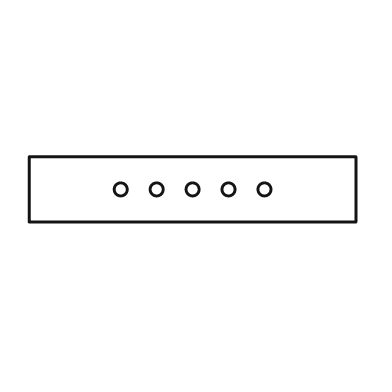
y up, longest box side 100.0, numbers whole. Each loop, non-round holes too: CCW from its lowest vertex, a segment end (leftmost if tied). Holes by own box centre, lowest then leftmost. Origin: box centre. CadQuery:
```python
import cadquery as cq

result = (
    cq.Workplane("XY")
    .moveTo(-50.0, -10.0)
    .lineTo(50.0, -10.0)
    .lineTo(50.0, 10.0)
    .lineTo(-50.0, 10.0)
    .close()
    .moveTo(-22.0, 0.0)
    .circle(2.0)
    .moveTo(-11.0, 0.0)
    .circle(2.0)
    .moveTo(0.0, 0.0)
    .circle(2.0)
    .moveTo(11.0, 0.0)
    .circle(2.0)
    .moveTo(22.0, 0.0)
    .circle(2.0)
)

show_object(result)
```